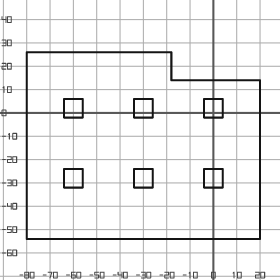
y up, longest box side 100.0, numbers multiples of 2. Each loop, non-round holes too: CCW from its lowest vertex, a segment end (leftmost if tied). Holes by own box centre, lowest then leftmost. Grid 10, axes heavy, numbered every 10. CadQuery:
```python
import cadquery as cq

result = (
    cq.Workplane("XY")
    .moveTo(-80.0, -54.0)
    .lineTo(20.0, -54.0)
    .lineTo(20.0, 14.0)
    .lineTo(-18.0, 14.0)
    .lineTo(-18.0, 26.0)
    .lineTo(-80.0, 26.0)
    .close()
    .moveTo(-64.0, -32.0)
    .lineTo(-56.0, -32.0)
    .lineTo(-56.0, -24.0)
    .lineTo(-64.0, -24.0)
    .close()
    .moveTo(-34.0, -32.0)
    .lineTo(-26.0, -32.0)
    .lineTo(-26.0, -24.0)
    .lineTo(-34.0, -24.0)
    .close()
    .moveTo(-4.0, -32.0)
    .lineTo(4.0, -32.0)
    .lineTo(4.0, -24.0)
    .lineTo(-4.0, -24.0)
    .close()
    .moveTo(-64.0, -2.0)
    .lineTo(-56.0, -2.0)
    .lineTo(-56.0, 6.0)
    .lineTo(-64.0, 6.0)
    .close()
    .moveTo(-34.0, -2.0)
    .lineTo(-26.0, -2.0)
    .lineTo(-26.0, 6.0)
    .lineTo(-34.0, 6.0)
    .close()
    .moveTo(-4.0, -2.0)
    .lineTo(4.0, -2.0)
    .lineTo(4.0, 6.0)
    .lineTo(-4.0, 6.0)
    .close()
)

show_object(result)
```